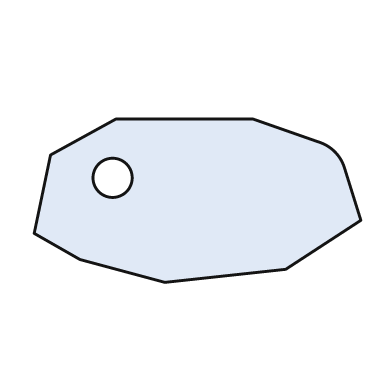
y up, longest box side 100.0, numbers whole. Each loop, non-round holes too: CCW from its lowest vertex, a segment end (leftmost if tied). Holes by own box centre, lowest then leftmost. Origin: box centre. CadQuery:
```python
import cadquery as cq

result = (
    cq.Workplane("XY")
    .moveTo(-10.0, -25.0)
    .lineTo(27.0, -21.0)
    .lineTo(50.0, -6.0)
    .lineTo(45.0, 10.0)
    .threePointArc((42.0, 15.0), (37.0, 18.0))
    .lineTo(17.0, 25.0)
    .lineTo(-25.0, 25.0)
    .lineTo(-45.0, 14.0)
    .lineTo(-50.0, -10.0)
    .lineTo(-36.0, -18.0)
    .close()
    .moveTo(-26.0, 7.0)
    .circle(6.0)
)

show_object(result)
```